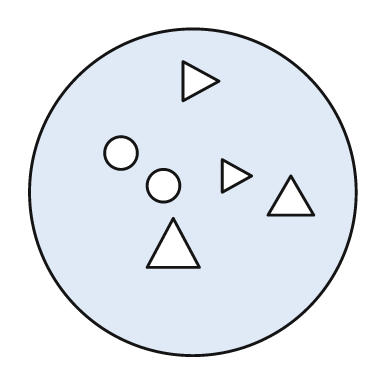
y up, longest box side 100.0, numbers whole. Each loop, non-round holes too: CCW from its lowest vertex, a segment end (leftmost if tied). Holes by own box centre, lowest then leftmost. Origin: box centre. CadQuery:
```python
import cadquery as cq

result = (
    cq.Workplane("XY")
    .moveTo(0.0, 0.0)
    .circle(50.0)
    .moveTo(-14.0, -23.0)
    .lineTo(2.0, -23.0)
    .lineTo(-6.0, -8.0)
    .close()
    .moveTo(23.0, -7.0)
    .lineTo(37.0, -7.0)
    .lineTo(30.0, 5.0)
    .close()
    .moveTo(-9.0, 2.0)
    .circle(5.0)
    .moveTo(9.0, 0.0)
    .lineTo(18.0, 5.0)
    .lineTo(9.0, 10.0)
    .close()
    .moveTo(-22.0, 12.0)
    .circle(5.0)
    .moveTo(-3.0, 28.0)
    .lineTo(8.0, 34.0)
    .lineTo(-3.0, 40.0)
    .close()
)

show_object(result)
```